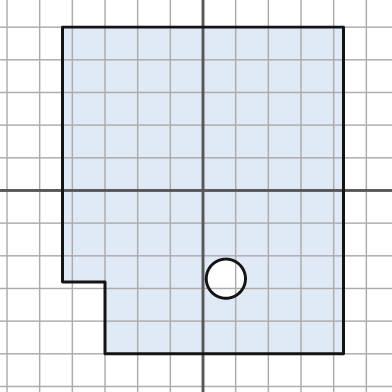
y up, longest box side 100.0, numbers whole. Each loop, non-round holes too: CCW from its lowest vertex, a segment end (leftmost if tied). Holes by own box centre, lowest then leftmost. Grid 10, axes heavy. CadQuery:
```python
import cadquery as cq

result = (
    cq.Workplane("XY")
    .moveTo(-30.0, -50.0)
    .lineTo(43.0, -50.0)
    .lineTo(43.0, 50.0)
    .lineTo(-43.0, 50.0)
    .lineTo(-43.0, -28.0)
    .lineTo(-30.0, -28.0)
    .close()
    .moveTo(7.0, -27.0)
    .circle(6.0)
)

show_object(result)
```